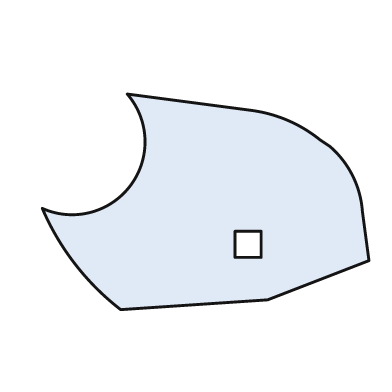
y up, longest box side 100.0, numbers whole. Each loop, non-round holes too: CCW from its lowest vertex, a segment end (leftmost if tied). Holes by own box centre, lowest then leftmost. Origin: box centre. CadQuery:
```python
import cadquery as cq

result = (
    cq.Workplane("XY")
    .moveTo(-26.0, -33.0)
    .lineTo(19.0, -30.0)
    .lineTo(50.0, -18.0)
    .lineTo(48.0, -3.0)
    .threePointArc((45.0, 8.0), (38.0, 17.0))
    .lineTo(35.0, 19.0)
    .threePointArc((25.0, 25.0), (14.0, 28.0))
    .lineTo(-24.0, 33.0)
    .threePointArc((-23.0, 5.0), (-50.0, -2.0))
    .threePointArc((-40.0, -19.0), (-26.0, -33.0))
    .close()
    .moveTo(9.0, -17.0)
    .lineTo(17.0, -17.0)
    .lineTo(17.0, -9.0)
    .lineTo(9.0, -9.0)
    .close()
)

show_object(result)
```